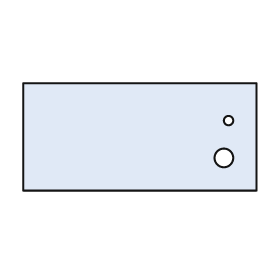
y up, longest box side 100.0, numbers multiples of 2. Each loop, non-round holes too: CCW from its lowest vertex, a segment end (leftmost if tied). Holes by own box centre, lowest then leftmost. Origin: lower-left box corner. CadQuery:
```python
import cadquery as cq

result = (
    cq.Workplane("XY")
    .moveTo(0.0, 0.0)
    .lineTo(100.0, 0.0)
    .lineTo(100.0, 46.0)
    .lineTo(0.0, 46.0)
    .close()
    .moveTo(86.0, 14.0)
    .circle(4.0)
    .moveTo(88.0, 30.0)
    .circle(2.0)
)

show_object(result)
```